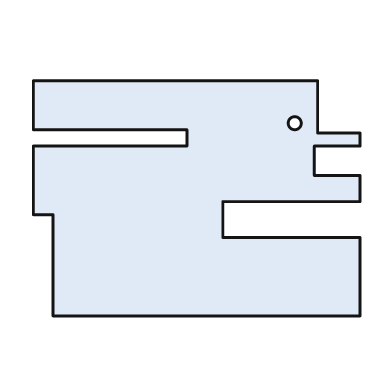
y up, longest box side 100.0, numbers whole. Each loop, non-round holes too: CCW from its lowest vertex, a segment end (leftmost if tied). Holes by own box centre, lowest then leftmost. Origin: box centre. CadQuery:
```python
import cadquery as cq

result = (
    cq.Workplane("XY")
    .moveTo(-44.0, -36.0)
    .lineTo(50.0, -36.0)
    .lineTo(50.0, -12.0)
    .lineTo(8.0, -12.0)
    .lineTo(8.0, -1.0)
    .lineTo(50.0, -1.0)
    .lineTo(50.0, 7.0)
    .lineTo(36.0, 7.0)
    .lineTo(36.0, 16.0)
    .lineTo(50.0, 16.0)
    .lineTo(50.0, 20.0)
    .lineTo(37.0, 20.0)
    .lineTo(37.0, 36.0)
    .lineTo(-50.0, 36.0)
    .lineTo(-50.0, 21.0)
    .lineTo(-3.0, 21.0)
    .lineTo(-3.0, 16.0)
    .lineTo(-50.0, 16.0)
    .lineTo(-50.0, -5.0)
    .lineTo(-44.0, -5.0)
    .close()
    .moveTo(30.0, 23.0)
    .circle(2.0)
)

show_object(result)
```